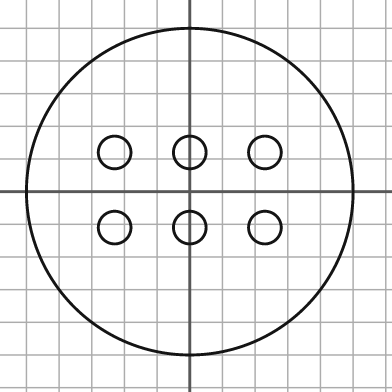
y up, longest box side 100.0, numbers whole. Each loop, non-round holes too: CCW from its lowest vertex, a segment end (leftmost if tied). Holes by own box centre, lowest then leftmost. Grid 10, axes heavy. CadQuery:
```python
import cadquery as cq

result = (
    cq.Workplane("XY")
    .moveTo(0.0, 0.0)
    .circle(50.0)
    .moveTo(-23.0, -11.0)
    .circle(5.0)
    .moveTo(0.0, -11.0)
    .circle(5.0)
    .moveTo(23.0, -11.0)
    .circle(5.0)
    .moveTo(-23.0, 12.0)
    .circle(5.0)
    .moveTo(0.0, 12.0)
    .circle(5.0)
    .moveTo(23.0, 12.0)
    .circle(5.0)
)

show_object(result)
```